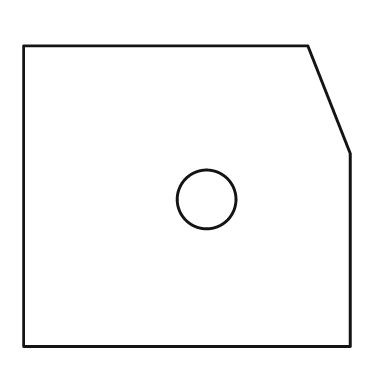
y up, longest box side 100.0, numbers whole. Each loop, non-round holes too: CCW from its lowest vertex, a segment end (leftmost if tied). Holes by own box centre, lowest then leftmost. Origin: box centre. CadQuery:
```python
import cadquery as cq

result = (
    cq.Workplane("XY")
    .moveTo(-50.0, -46.0)
    .lineTo(50.0, -46.0)
    .lineTo(50.0, 13.0)
    .lineTo(37.0, 46.0)
    .lineTo(-50.0, 46.0)
    .close()
    .moveTo(6.0, -1.0)
    .circle(9.0)
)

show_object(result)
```